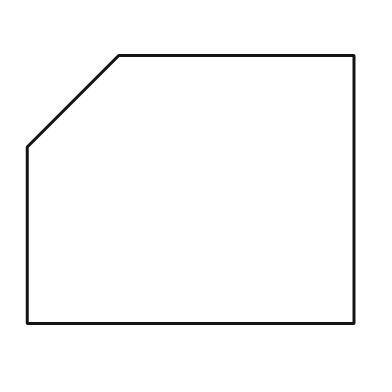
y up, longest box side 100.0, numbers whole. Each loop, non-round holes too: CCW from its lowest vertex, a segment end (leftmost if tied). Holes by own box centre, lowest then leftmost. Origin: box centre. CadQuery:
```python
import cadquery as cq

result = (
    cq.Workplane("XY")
    .moveTo(-50.0, -41.0)
    .lineTo(50.0, -41.0)
    .lineTo(50.0, 41.0)
    .lineTo(-22.0, 41.0)
    .lineTo(-50.0, 13.0)
    .close()
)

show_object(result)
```